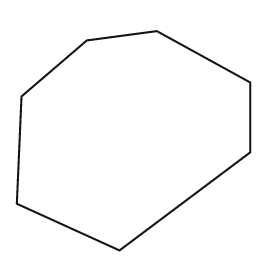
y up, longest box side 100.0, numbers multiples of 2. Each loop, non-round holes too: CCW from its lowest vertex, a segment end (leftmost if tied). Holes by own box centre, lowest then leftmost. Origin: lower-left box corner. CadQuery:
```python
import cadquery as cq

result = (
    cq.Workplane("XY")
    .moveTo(44.0, 0.0)
    .lineTo(100.0, 42.0)
    .lineTo(100.0, 72.0)
    .lineTo(60.0, 94.0)
    .lineTo(30.0, 90.0)
    .lineTo(2.0, 66.0)
    .lineTo(0.0, 20.0)
    .close()
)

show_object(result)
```